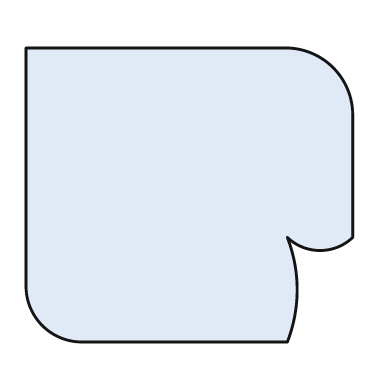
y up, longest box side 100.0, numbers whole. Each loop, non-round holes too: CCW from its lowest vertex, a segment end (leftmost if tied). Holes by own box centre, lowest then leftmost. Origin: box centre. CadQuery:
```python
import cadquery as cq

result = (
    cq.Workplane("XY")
    .moveTo(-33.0, -45.0)
    .lineTo(30.0, -45.0)
    .threePointArc((33.0, -29.0), (30.0, -13.0))
    .threePointArc((40.0, -17.0), (50.0, -13.0))
    .lineTo(50.0, 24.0)
    .threePointArc((44.0, 39.0), (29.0, 45.0))
    .lineTo(-50.0, 45.0)
    .lineTo(-50.0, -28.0)
    .threePointArc((-45.0, -40.0), (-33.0, -45.0))
    .close()
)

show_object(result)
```